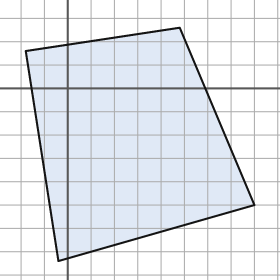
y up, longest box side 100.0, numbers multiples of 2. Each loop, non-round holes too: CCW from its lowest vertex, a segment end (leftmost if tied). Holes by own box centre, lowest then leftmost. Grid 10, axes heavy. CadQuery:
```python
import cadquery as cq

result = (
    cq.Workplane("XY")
    .moveTo(-4.0, -74.0)
    .lineTo(80.0, -50.0)
    .lineTo(48.0, 26.0)
    .lineTo(-18.0, 16.0)
    .close()
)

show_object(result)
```